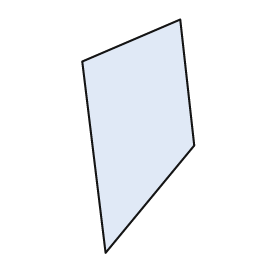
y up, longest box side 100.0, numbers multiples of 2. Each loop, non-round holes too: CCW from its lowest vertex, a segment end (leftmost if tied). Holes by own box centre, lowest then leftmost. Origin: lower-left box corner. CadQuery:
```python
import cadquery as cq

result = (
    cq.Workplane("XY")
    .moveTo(10.0, 0.0)
    .lineTo(48.0, 46.0)
    .lineTo(42.0, 100.0)
    .lineTo(0.0, 82.0)
    .close()
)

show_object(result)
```